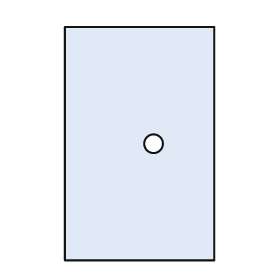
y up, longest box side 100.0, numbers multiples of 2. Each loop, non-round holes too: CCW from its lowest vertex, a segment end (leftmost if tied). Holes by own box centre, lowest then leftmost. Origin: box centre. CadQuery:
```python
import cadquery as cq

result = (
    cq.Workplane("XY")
    .moveTo(-32.0, -50.0)
    .lineTo(32.0, -50.0)
    .lineTo(32.0, 50.0)
    .lineTo(-32.0, 50.0)
    .close()
    .moveTo(6.0, 0.0)
    .circle(4.0)
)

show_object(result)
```